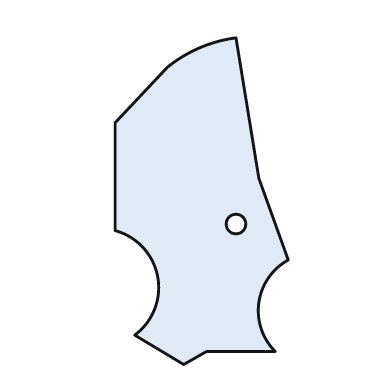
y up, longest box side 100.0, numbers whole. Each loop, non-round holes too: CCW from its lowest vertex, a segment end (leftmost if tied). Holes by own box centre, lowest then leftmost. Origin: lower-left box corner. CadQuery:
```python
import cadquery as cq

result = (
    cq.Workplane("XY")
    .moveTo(21.0, 0.0)
    .lineTo(28.0, 4.0)
    .lineTo(49.0, 4.0)
    .threePointArc((44.0, 19.0), (53.0, 32.0))
    .lineTo(44.0, 57.0)
    .lineTo(37.0, 100.0)
    .threePointArc((26.0, 97.0), (16.0, 91.0))
    .lineTo(0.0, 74.0)
    .lineTo(0.0, 41.0)
    .threePointArc((13.0, 27.0), (6.0, 9.0))
    .close()
    .moveTo(37.0, 43.0)
    .circle(3.0)
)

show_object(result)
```